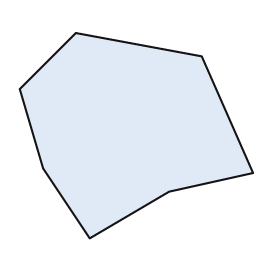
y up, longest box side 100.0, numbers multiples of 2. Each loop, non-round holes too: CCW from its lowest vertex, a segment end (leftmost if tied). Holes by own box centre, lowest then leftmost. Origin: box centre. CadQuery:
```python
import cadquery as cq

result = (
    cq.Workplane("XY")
    .moveTo(-20.0, -44.0)
    .lineTo(14.0, -24.0)
    .lineTo(50.0, -16.0)
    .lineTo(28.0, 34.0)
    .lineTo(-26.0, 44.0)
    .lineTo(-50.0, 20.0)
    .lineTo(-40.0, -14.0)
    .close()
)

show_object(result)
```